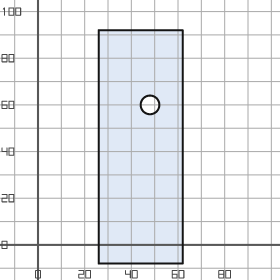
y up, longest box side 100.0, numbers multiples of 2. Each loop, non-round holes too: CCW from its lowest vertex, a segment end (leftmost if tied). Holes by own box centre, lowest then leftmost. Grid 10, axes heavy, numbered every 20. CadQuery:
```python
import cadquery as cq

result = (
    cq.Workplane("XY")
    .moveTo(26.0, -8.0)
    .lineTo(62.0, -8.0)
    .lineTo(62.0, 92.0)
    .lineTo(26.0, 92.0)
    .close()
    .moveTo(48.0, 60.0)
    .circle(4.0)
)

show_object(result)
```